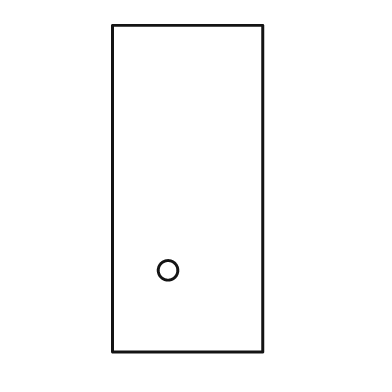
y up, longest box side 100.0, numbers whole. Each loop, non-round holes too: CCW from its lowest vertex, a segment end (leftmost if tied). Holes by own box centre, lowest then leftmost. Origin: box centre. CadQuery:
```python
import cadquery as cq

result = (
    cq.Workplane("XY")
    .moveTo(-23.0, -50.0)
    .lineTo(23.0, -50.0)
    .lineTo(23.0, 50.0)
    .lineTo(-23.0, 50.0)
    .close()
    .moveTo(-6.0, -25.0)
    .circle(3.0)
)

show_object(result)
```